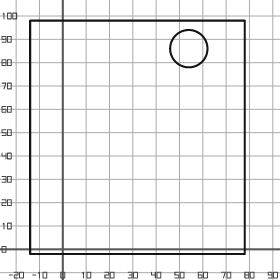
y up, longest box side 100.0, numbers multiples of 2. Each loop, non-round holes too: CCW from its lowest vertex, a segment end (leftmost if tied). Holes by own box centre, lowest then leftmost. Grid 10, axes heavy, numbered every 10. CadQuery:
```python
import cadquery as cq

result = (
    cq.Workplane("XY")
    .moveTo(-14.0, -2.0)
    .lineTo(78.0, -2.0)
    .lineTo(78.0, 98.0)
    .lineTo(-14.0, 98.0)
    .close()
    .moveTo(54.0, 86.0)
    .circle(8.0)
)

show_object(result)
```